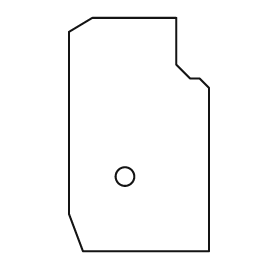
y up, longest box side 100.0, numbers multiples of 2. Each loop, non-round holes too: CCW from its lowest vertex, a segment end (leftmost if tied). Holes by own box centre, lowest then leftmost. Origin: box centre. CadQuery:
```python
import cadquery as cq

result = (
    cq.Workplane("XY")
    .moveTo(-24.0, -50.0)
    .lineTo(30.0, -50.0)
    .lineTo(30.0, 20.0)
    .lineTo(26.0, 24.0)
    .lineTo(22.0, 24.0)
    .lineTo(16.0, 30.0)
    .lineTo(16.0, 50.0)
    .lineTo(-20.0, 50.0)
    .lineTo(-30.0, 44.0)
    .lineTo(-30.0, -34.0)
    .close()
    .moveTo(-6.0, -18.0)
    .circle(4.0)
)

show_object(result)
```